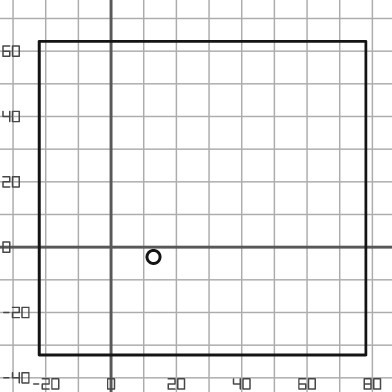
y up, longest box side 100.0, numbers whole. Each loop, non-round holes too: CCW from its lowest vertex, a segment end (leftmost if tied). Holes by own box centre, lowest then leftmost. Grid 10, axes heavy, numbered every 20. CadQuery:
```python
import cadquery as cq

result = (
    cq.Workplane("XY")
    .moveTo(-22.0, -33.0)
    .lineTo(78.0, -33.0)
    .lineTo(78.0, 63.0)
    .lineTo(-22.0, 63.0)
    .close()
    .moveTo(13.0, -3.0)
    .circle(2.0)
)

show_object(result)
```